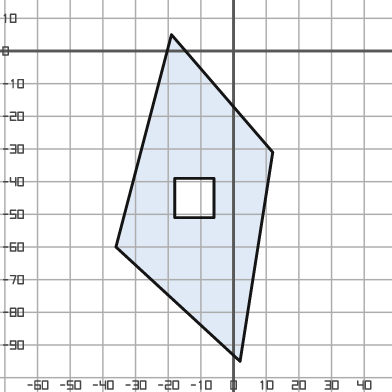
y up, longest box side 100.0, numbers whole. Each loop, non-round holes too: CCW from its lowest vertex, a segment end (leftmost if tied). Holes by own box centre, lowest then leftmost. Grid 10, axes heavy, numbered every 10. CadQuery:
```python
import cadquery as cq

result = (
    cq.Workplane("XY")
    .moveTo(2.0, -95.0)
    .lineTo(12.0, -31.0)
    .lineTo(-19.0, 5.0)
    .lineTo(-36.0, -60.0)
    .close()
    .moveTo(-18.0, -51.0)
    .lineTo(-6.0, -51.0)
    .lineTo(-6.0, -39.0)
    .lineTo(-18.0, -39.0)
    .close()
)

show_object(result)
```